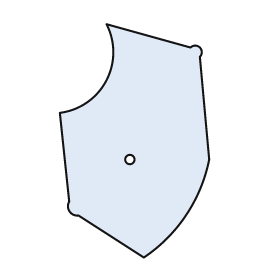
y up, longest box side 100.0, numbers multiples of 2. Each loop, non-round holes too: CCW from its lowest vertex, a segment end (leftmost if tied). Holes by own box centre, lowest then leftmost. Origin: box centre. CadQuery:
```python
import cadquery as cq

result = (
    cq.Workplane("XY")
    .moveTo(4.0, -50.0)
    .threePointArc((22.0, -32.0), (32.0, -8.0))
    .lineTo(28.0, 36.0)
    .threePointArc((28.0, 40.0), (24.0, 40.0))
    .lineTo(-12.0, 50.0)
    .threePointArc((-12.0, 26.0), (-32.0, 12.0))
    .lineTo(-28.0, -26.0)
    .threePointArc((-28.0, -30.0), (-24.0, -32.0))
    .close()
    .moveTo(-2.0, -8.0)
    .circle(2.0)
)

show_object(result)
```